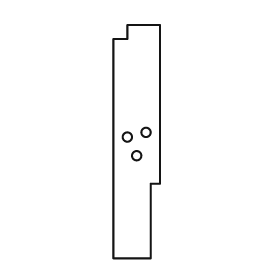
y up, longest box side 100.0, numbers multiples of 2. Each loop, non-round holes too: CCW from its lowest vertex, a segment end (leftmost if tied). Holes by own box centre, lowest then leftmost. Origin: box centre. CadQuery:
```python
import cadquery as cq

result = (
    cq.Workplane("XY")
    .moveTo(-10.0, -50.0)
    .lineTo(6.0, -50.0)
    .lineTo(6.0, -18.0)
    .lineTo(10.0, -18.0)
    .lineTo(10.0, 50.0)
    .lineTo(-4.0, 50.0)
    .lineTo(-4.0, 44.0)
    .lineTo(-10.0, 44.0)
    .close()
    .moveTo(0.0, -6.0)
    .circle(2.0)
    .moveTo(-4.0, 2.0)
    .circle(2.0)
    .moveTo(4.0, 4.0)
    .circle(2.0)
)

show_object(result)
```